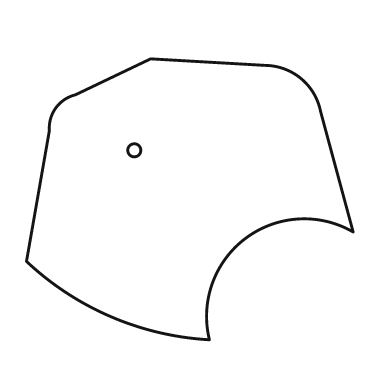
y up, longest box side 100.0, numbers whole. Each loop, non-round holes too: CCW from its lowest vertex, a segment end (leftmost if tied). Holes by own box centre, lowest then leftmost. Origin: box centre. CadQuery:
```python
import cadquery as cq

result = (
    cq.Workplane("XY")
    .moveTo(6.0, -43.0)
    .threePointArc((17.0, -12.0), (50.0, -10.0))
    .lineTo(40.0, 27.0)
    .threePointArc((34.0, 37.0), (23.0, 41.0))
    .lineTo(-12.0, 43.0)
    .lineTo(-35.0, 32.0)
    .threePointArc((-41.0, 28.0), (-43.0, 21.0))
    .lineTo(-50.0, -19.0)
    .threePointArc((-24.0, -36.0), (6.0, -43.0))
    .close()
    .moveTo(-17.0, 15.0)
    .circle(2.0)
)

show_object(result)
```